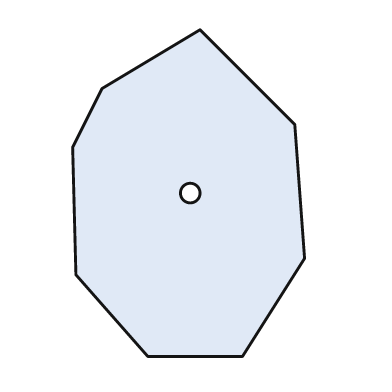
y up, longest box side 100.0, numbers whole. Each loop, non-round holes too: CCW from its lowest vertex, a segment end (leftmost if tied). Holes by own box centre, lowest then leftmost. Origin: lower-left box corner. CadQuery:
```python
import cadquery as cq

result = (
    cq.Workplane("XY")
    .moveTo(23.0, 0.0)
    .lineTo(52.0, 0.0)
    .lineTo(71.0, 30.0)
    .lineTo(68.0, 71.0)
    .lineTo(39.0, 100.0)
    .lineTo(9.0, 82.0)
    .lineTo(0.0, 64.0)
    .lineTo(1.0, 25.0)
    .close()
    .moveTo(36.0, 50.0)
    .circle(3.0)
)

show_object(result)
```